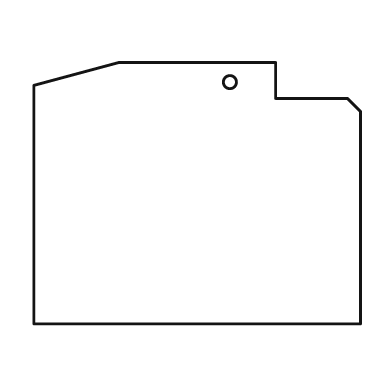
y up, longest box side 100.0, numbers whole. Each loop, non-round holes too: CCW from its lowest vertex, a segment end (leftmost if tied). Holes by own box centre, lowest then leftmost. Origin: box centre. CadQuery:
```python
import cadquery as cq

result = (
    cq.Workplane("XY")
    .moveTo(-50.0, -40.0)
    .lineTo(50.0, -40.0)
    .lineTo(50.0, 25.0)
    .lineTo(46.0, 29.0)
    .lineTo(24.0, 29.0)
    .lineTo(24.0, 40.0)
    .lineTo(-24.0, 40.0)
    .lineTo(-50.0, 33.0)
    .close()
    .moveTo(10.0, 34.0)
    .circle(2.0)
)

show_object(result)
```